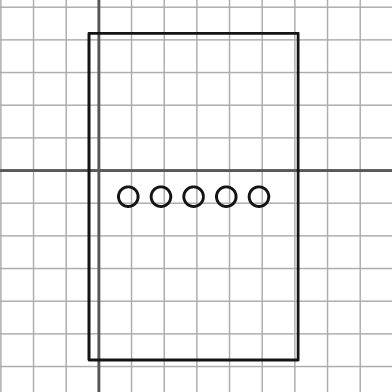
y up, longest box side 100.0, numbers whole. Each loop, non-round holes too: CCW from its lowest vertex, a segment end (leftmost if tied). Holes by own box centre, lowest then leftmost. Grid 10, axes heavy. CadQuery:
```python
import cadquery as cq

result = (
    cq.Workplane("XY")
    .moveTo(-3.0, -58.0)
    .lineTo(61.0, -58.0)
    .lineTo(61.0, 42.0)
    .lineTo(-3.0, 42.0)
    .close()
    .moveTo(9.0, -8.0)
    .circle(3.0)
    .moveTo(19.0, -8.0)
    .circle(3.0)
    .moveTo(29.0, -8.0)
    .circle(3.0)
    .moveTo(39.0, -8.0)
    .circle(3.0)
    .moveTo(49.0, -8.0)
    .circle(3.0)
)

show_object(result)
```